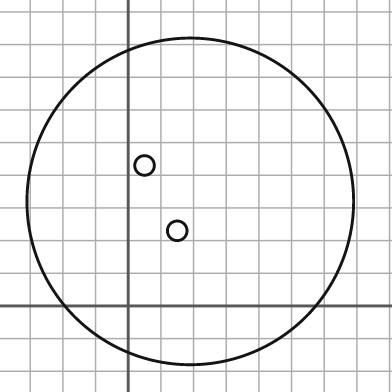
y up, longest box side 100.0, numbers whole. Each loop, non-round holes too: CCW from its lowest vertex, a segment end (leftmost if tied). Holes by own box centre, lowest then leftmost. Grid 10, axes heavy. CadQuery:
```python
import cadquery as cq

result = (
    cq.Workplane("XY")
    .moveTo(19.0, 32.0)
    .circle(50.0)
    .moveTo(15.0, 23.0)
    .circle(3.0)
    .moveTo(5.0, 43.0)
    .circle(3.0)
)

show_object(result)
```